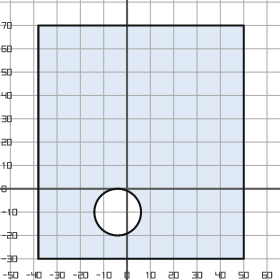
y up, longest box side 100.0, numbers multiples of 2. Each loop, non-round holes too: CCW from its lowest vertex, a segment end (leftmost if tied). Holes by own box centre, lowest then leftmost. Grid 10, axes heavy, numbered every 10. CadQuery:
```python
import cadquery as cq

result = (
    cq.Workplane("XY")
    .moveTo(-38.0, -30.0)
    .lineTo(50.0, -30.0)
    .lineTo(50.0, 70.0)
    .lineTo(-38.0, 70.0)
    .close()
    .moveTo(-4.0, -10.0)
    .circle(10.0)
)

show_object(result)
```